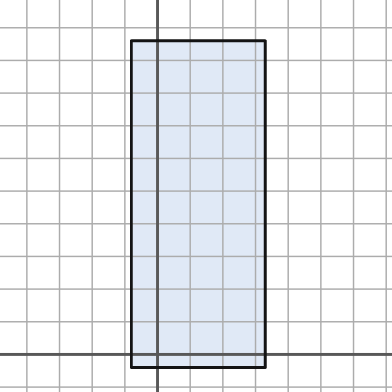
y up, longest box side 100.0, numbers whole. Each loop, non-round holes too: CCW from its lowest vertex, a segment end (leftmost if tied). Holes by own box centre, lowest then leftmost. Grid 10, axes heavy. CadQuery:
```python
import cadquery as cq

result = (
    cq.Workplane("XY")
    .moveTo(-8.0, -4.0)
    .lineTo(33.0, -4.0)
    .lineTo(33.0, 96.0)
    .lineTo(-8.0, 96.0)
    .close()
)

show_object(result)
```